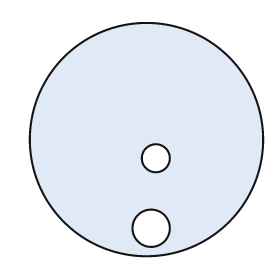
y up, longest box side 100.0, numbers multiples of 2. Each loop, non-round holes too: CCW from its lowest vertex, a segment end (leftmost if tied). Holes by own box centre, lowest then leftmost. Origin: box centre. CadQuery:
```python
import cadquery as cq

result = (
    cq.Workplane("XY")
    .moveTo(0.0, 0.0)
    .circle(50.0)
    .moveTo(2.0, -38.0)
    .circle(8.0)
    .moveTo(4.0, -8.0)
    .circle(6.0)
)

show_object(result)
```